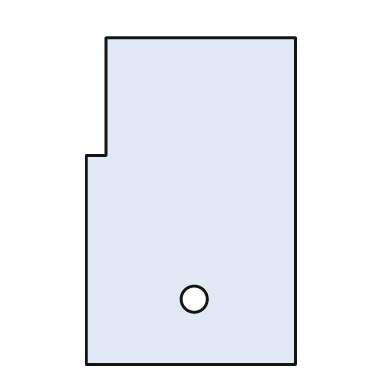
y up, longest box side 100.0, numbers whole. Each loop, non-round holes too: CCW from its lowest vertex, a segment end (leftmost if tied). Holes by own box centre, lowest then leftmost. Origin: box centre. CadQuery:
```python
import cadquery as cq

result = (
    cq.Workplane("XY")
    .moveTo(-32.0, -50.0)
    .lineTo(32.0, -50.0)
    .lineTo(32.0, 50.0)
    .lineTo(-26.0, 50.0)
    .lineTo(-26.0, 14.0)
    .lineTo(-32.0, 14.0)
    .close()
    .moveTo(1.0, -30.0)
    .circle(4.0)
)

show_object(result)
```